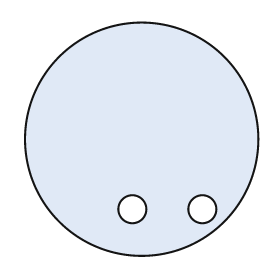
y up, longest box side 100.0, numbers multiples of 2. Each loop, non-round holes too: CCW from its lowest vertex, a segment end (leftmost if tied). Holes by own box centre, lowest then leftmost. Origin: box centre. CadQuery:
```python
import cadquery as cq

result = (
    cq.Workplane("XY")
    .moveTo(0.0, 0.0)
    .circle(50.0)
    .moveTo(-4.0, -30.0)
    .circle(6.0)
    .moveTo(26.0, -30.0)
    .circle(6.0)
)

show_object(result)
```